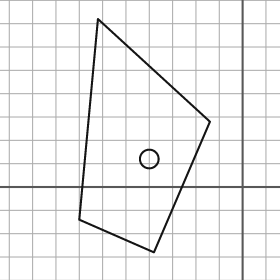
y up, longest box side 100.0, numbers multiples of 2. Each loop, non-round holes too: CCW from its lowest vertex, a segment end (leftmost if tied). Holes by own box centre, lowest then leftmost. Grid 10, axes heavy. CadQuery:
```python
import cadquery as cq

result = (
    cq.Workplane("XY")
    .moveTo(-38.0, -28.0)
    .lineTo(-14.0, 28.0)
    .lineTo(-62.0, 72.0)
    .lineTo(-70.0, -14.0)
    .close()
    .moveTo(-40.0, 12.0)
    .circle(4.0)
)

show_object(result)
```